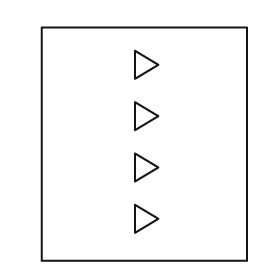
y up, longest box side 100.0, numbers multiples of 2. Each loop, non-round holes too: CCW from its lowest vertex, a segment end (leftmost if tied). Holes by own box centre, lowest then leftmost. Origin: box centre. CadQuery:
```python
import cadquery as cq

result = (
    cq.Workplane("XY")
    .moveTo(-44.0, -50.0)
    .lineTo(44.0, -50.0)
    .lineTo(44.0, 50.0)
    .lineTo(-44.0, 50.0)
    .close()
    .moveTo(-4.0, -38.0)
    .lineTo(6.0, -32.0)
    .lineTo(-4.0, -26.0)
    .close()
    .moveTo(-4.0, -16.0)
    .lineTo(6.0, -10.0)
    .lineTo(-4.0, -4.0)
    .close()
    .moveTo(-4.0, 6.0)
    .lineTo(6.0, 12.0)
    .lineTo(-4.0, 18.0)
    .close()
    .moveTo(-4.0, 28.0)
    .lineTo(6.0, 34.0)
    .lineTo(-4.0, 40.0)
    .close()
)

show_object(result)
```